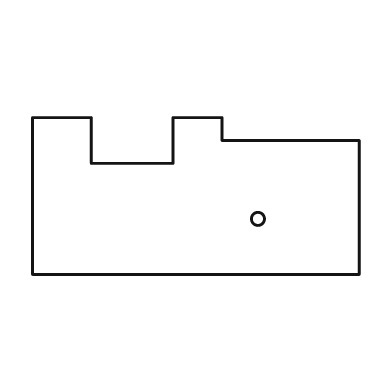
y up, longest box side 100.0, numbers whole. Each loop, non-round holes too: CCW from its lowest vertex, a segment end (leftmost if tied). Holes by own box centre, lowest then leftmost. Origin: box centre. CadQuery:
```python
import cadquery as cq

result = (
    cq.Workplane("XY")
    .moveTo(-50.0, -24.0)
    .lineTo(50.0, -24.0)
    .lineTo(50.0, 17.0)
    .lineTo(8.0, 17.0)
    .lineTo(8.0, 24.0)
    .lineTo(-7.0, 24.0)
    .lineTo(-7.0, 10.0)
    .lineTo(-32.0, 10.0)
    .lineTo(-32.0, 24.0)
    .lineTo(-50.0, 24.0)
    .close()
    .moveTo(19.0, -7.0)
    .circle(2.0)
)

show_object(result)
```